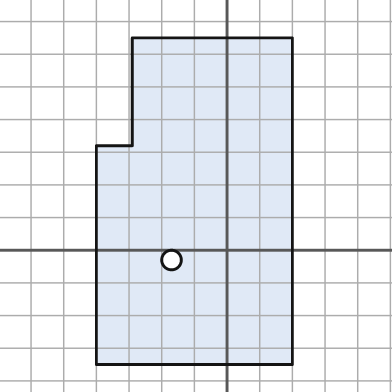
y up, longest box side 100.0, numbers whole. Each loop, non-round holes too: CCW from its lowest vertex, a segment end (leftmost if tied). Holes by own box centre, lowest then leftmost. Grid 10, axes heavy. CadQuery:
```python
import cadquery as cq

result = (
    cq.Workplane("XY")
    .moveTo(-40.0, -35.0)
    .lineTo(20.0, -35.0)
    .lineTo(20.0, 65.0)
    .lineTo(-29.0, 65.0)
    .lineTo(-29.0, 32.0)
    .lineTo(-40.0, 32.0)
    .close()
    .moveTo(-17.0, -3.0)
    .circle(3.0)
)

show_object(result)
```